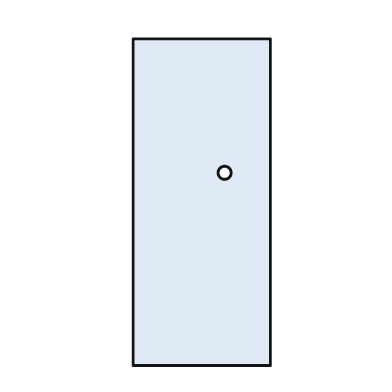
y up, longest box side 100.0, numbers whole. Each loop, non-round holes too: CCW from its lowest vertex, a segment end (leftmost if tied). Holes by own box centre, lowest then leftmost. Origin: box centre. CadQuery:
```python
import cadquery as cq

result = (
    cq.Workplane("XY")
    .moveTo(-21.0, -50.0)
    .lineTo(21.0, -50.0)
    .lineTo(21.0, 50.0)
    .lineTo(-21.0, 50.0)
    .close()
    .moveTo(7.0, 9.0)
    .circle(2.0)
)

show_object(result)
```